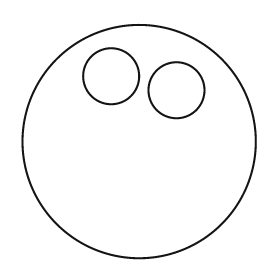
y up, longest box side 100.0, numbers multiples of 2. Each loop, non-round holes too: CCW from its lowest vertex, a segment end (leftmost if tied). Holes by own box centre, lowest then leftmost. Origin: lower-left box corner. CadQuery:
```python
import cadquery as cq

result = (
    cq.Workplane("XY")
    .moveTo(50.0, 50.0)
    .circle(50.0)
    .moveTo(66.0, 72.0)
    .circle(12.0)
    .moveTo(38.0, 78.0)
    .circle(12.0)
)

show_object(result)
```